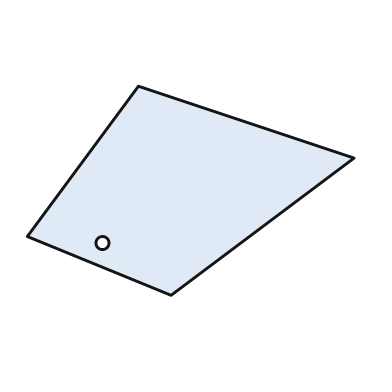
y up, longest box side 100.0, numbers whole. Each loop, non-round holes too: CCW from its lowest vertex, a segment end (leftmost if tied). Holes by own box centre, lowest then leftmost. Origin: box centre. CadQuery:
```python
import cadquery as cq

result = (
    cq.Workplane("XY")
    .moveTo(-6.0, -32.0)
    .lineTo(50.0, 10.0)
    .lineTo(-16.0, 32.0)
    .lineTo(-50.0, -14.0)
    .close()
    .moveTo(-27.0, -16.0)
    .circle(2.0)
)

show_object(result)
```